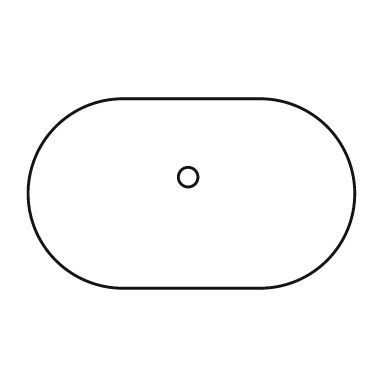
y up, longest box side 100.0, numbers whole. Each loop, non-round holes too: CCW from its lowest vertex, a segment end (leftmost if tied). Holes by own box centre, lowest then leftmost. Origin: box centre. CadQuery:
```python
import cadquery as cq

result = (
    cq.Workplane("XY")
    .moveTo(-21.0, -29.0)
    .lineTo(21.0, -29.0)
    .threePointArc((50.0, 0.0), (21.0, 29.0))
    .lineTo(-21.0, 29.0)
    .threePointArc((-50.0, 0.0), (-21.0, -29.0))
    .close()
    .moveTo(-1.0, 5.0)
    .circle(3.0)
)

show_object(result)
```